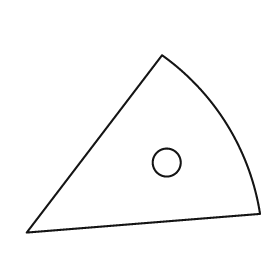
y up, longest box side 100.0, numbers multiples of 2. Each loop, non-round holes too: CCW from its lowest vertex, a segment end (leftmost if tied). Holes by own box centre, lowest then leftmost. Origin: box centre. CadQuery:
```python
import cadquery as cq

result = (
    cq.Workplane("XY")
    .moveTo(-50.0, -38.0)
    .lineTo(50.0, -30.0)
    .threePointArc((36.0, 8.0), (8.0, 38.0))
    .close()
    .moveTo(10.0, -8.0)
    .circle(6.0)
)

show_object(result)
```